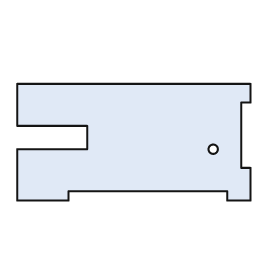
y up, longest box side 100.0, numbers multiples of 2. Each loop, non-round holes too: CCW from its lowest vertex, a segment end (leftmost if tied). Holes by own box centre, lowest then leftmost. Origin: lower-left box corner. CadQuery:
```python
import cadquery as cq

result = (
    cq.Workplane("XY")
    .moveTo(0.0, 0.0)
    .lineTo(22.0, 0.0)
    .lineTo(22.0, 4.0)
    .lineTo(90.0, 4.0)
    .lineTo(90.0, 0.0)
    .lineTo(100.0, 0.0)
    .lineTo(100.0, 14.0)
    .lineTo(96.0, 14.0)
    .lineTo(96.0, 42.0)
    .lineTo(100.0, 42.0)
    .lineTo(100.0, 50.0)
    .lineTo(0.0, 50.0)
    .lineTo(0.0, 32.0)
    .lineTo(30.0, 32.0)
    .lineTo(30.0, 22.0)
    .lineTo(0.0, 22.0)
    .close()
    .moveTo(84.0, 22.0)
    .circle(2.0)
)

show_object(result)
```